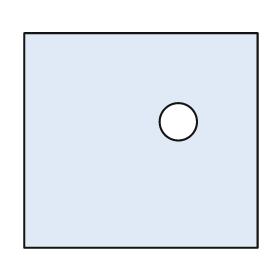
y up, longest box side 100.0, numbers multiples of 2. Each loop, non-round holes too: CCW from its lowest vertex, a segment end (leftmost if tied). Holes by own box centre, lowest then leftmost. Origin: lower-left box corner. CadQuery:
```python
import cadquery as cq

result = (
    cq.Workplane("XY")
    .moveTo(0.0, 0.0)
    .lineTo(100.0, 0.0)
    .lineTo(100.0, 92.0)
    .lineTo(0.0, 92.0)
    .close()
    .moveTo(66.0, 54.0)
    .circle(8.0)
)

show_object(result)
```